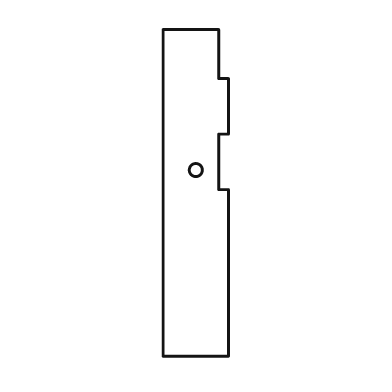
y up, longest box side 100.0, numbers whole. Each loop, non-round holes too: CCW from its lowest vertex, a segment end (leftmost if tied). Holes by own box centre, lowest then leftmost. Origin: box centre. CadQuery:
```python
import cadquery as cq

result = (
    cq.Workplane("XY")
    .moveTo(-10.0, -50.0)
    .lineTo(10.0, -50.0)
    .lineTo(10.0, 1.0)
    .lineTo(7.0, 1.0)
    .lineTo(7.0, 18.0)
    .lineTo(10.0, 18.0)
    .lineTo(10.0, 35.0)
    .lineTo(7.0, 35.0)
    .lineTo(7.0, 50.0)
    .lineTo(-10.0, 50.0)
    .close()
    .moveTo(0.0, 7.0)
    .circle(2.0)
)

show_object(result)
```